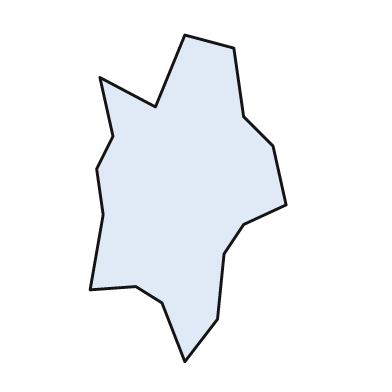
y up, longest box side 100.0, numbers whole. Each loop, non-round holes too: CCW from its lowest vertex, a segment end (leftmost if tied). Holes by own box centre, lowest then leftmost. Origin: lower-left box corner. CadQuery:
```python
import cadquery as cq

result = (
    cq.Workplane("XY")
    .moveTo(29.0, 0.0)
    .lineTo(39.0, 13.0)
    .lineTo(41.0, 33.0)
    .lineTo(47.0, 42.0)
    .lineTo(60.0, 48.0)
    .lineTo(56.0, 66.0)
    .lineTo(47.0, 75.0)
    .lineTo(44.0, 96.0)
    .lineTo(29.0, 100.0)
    .lineTo(20.0, 78.0)
    .lineTo(3.0, 87.0)
    .lineTo(7.0, 69.0)
    .lineTo(2.0, 59.0)
    .lineTo(4.0, 45.0)
    .lineTo(0.0, 22.0)
    .lineTo(14.0, 23.0)
    .lineTo(22.0, 18.0)
    .close()
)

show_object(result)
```